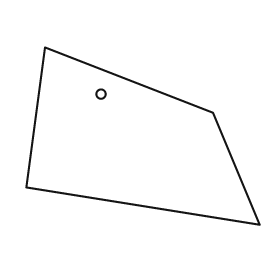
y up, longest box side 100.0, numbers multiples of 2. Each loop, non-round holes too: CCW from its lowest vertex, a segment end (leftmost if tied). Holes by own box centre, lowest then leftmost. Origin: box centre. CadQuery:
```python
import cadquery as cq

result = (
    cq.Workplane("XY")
    .moveTo(50.0, -38.0)
    .lineTo(30.0, 10.0)
    .lineTo(-42.0, 38.0)
    .lineTo(-50.0, -22.0)
    .close()
    .moveTo(-18.0, 18.0)
    .circle(2.0)
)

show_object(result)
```